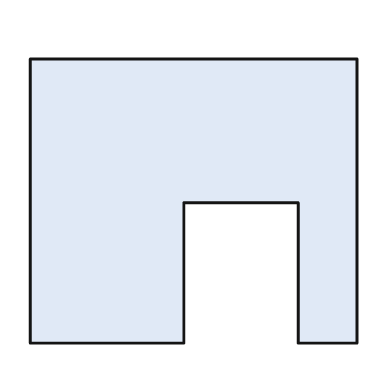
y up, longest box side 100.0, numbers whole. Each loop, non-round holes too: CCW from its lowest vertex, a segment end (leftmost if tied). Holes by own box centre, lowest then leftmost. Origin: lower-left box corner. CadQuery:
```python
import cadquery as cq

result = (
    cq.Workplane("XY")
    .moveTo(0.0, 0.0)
    .lineTo(47.0, 0.0)
    .lineTo(47.0, 43.0)
    .lineTo(82.0, 43.0)
    .lineTo(82.0, 0.0)
    .lineTo(100.0, 0.0)
    .lineTo(100.0, 87.0)
    .lineTo(0.0, 87.0)
    .close()
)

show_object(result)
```